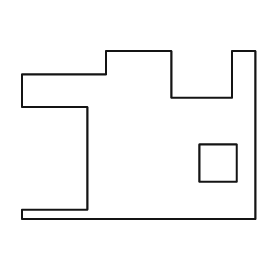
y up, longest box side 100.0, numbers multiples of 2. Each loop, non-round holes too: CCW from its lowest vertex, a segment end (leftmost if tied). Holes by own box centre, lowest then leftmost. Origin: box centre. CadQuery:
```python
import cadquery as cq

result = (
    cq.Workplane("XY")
    .moveTo(-50.0, -36.0)
    .lineTo(50.0, -36.0)
    .lineTo(50.0, 36.0)
    .lineTo(40.0, 36.0)
    .lineTo(40.0, 16.0)
    .lineTo(14.0, 16.0)
    .lineTo(14.0, 36.0)
    .lineTo(-14.0, 36.0)
    .lineTo(-14.0, 26.0)
    .lineTo(-50.0, 26.0)
    .lineTo(-50.0, 12.0)
    .lineTo(-22.0, 12.0)
    .lineTo(-22.0, -32.0)
    .lineTo(-50.0, -32.0)
    .close()
    .moveTo(26.0, -20.0)
    .lineTo(42.0, -20.0)
    .lineTo(42.0, -4.0)
    .lineTo(26.0, -4.0)
    .close()
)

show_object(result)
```